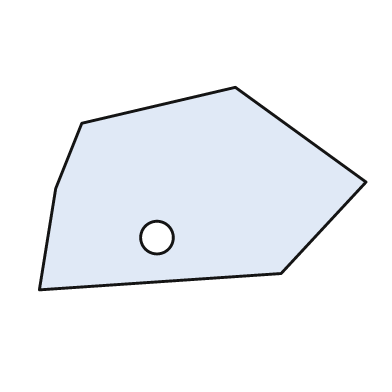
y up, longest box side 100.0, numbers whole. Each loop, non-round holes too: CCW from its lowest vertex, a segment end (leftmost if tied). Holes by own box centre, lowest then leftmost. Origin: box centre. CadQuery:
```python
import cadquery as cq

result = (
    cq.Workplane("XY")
    .moveTo(-50.0, -31.0)
    .lineTo(24.0, -26.0)
    .lineTo(50.0, 2.0)
    .lineTo(10.0, 31.0)
    .lineTo(-37.0, 20.0)
    .lineTo(-45.0, 0.0)
    .close()
    .moveTo(-14.0, -15.0)
    .circle(5.0)
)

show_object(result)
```